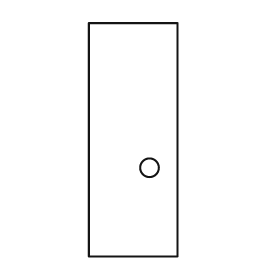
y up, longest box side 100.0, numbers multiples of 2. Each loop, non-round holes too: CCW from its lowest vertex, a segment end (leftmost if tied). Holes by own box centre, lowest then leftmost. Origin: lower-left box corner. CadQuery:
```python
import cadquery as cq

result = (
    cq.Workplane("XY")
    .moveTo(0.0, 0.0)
    .lineTo(38.0, 0.0)
    .lineTo(38.0, 100.0)
    .lineTo(0.0, 100.0)
    .close()
    .moveTo(26.0, 38.0)
    .circle(4.0)
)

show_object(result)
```